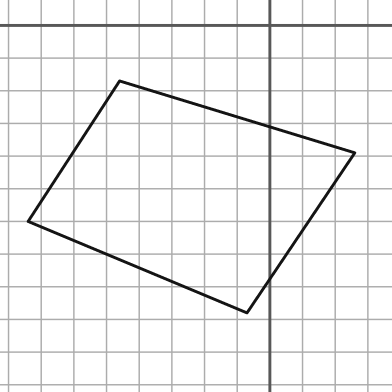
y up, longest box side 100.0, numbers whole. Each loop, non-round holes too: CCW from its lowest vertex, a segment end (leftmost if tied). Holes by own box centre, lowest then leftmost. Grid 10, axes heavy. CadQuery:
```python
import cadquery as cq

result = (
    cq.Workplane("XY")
    .moveTo(-7.0, -88.0)
    .lineTo(26.0, -39.0)
    .lineTo(-46.0, -17.0)
    .lineTo(-74.0, -60.0)
    .close()
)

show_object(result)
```